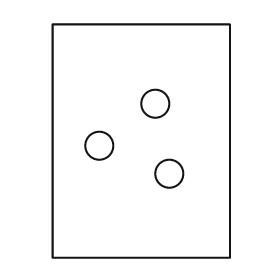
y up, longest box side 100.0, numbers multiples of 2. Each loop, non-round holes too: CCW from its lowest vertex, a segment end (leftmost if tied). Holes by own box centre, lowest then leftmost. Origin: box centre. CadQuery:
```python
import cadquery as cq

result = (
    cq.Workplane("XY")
    .moveTo(-38.0, -50.0)
    .lineTo(38.0, -50.0)
    .lineTo(38.0, 50.0)
    .lineTo(-38.0, 50.0)
    .close()
    .moveTo(12.0, -14.0)
    .circle(6.0)
    .moveTo(-18.0, -2.0)
    .circle(6.0)
    .moveTo(6.0, 16.0)
    .circle(6.0)
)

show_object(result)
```